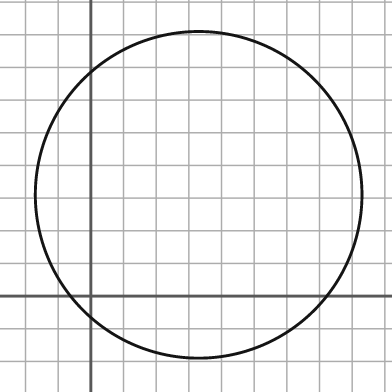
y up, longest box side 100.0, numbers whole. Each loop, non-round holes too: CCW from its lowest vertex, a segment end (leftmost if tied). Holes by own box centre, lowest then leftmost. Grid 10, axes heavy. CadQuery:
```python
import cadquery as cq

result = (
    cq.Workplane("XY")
    .moveTo(33.0, 31.0)
    .circle(50.0)
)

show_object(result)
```